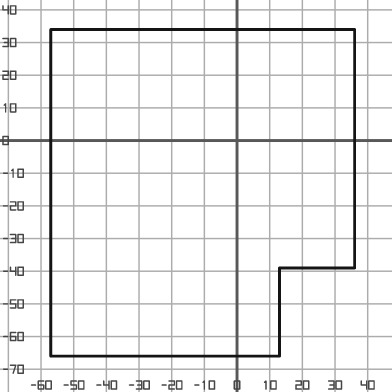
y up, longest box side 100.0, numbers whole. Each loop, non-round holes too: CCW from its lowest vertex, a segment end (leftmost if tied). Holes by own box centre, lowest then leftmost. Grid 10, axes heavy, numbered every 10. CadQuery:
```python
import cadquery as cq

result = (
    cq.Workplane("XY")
    .moveTo(-57.0, -66.0)
    .lineTo(13.0, -66.0)
    .lineTo(13.0, -39.0)
    .lineTo(36.0, -39.0)
    .lineTo(36.0, 34.0)
    .lineTo(-57.0, 34.0)
    .close()
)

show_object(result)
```